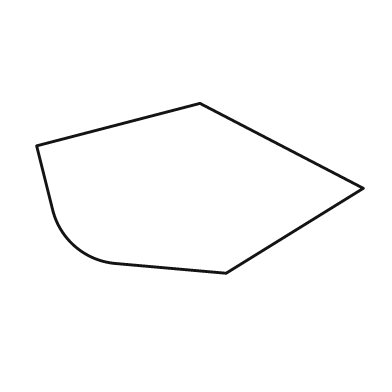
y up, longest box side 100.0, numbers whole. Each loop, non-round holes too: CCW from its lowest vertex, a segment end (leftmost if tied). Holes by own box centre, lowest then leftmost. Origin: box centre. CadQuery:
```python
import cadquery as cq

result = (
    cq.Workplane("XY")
    .moveTo(8.0, -26.0)
    .lineTo(50.0, 0.0)
    .lineTo(0.0, 26.0)
    .lineTo(-50.0, 13.0)
    .lineTo(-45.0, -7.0)
    .threePointArc((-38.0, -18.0), (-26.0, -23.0))
    .close()
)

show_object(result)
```